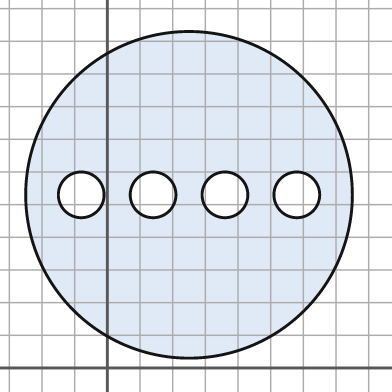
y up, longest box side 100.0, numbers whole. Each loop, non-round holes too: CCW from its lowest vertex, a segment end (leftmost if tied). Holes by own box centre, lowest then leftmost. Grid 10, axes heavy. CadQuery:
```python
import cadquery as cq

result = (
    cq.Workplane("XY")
    .moveTo(25.0, 53.0)
    .circle(50.0)
    .moveTo(-8.0, 53.0)
    .circle(7.0)
    .moveTo(14.0, 53.0)
    .circle(7.0)
    .moveTo(36.0, 53.0)
    .circle(7.0)
    .moveTo(58.0, 53.0)
    .circle(7.0)
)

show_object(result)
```